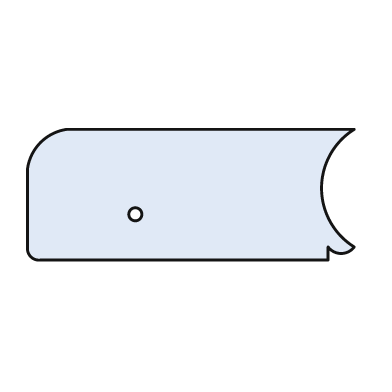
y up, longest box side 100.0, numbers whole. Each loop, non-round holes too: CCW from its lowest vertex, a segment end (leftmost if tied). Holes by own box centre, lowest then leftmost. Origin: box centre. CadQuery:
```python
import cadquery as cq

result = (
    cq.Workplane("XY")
    .moveTo(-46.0, -20.0)
    .lineTo(42.0, -20.0)
    .lineTo(42.0, -16.0)
    .threePointArc((46.0, -18.0), (50.0, -16.0))
    .threePointArc((40.0, 2.0), (50.0, 20.0))
    .lineTo(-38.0, 20.0)
    .threePointArc((-46.0, 16.0), (-50.0, 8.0))
    .lineTo(-50.0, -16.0)
    .threePointArc((-49.0, -19.0), (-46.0, -20.0))
    .close()
    .moveTo(-17.0, -6.0)
    .circle(2.0)
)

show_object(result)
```